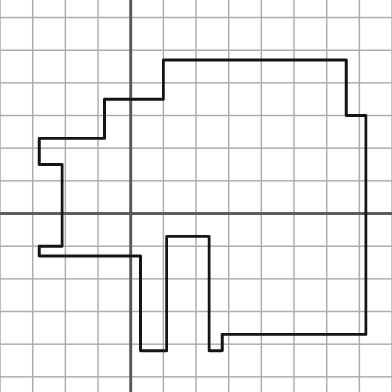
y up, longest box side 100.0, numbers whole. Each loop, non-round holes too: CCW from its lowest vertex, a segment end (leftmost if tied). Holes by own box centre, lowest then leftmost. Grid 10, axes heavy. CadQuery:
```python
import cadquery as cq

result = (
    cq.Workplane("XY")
    .moveTo(3.0, -42.0)
    .lineTo(11.0, -42.0)
    .lineTo(11.0, -7.0)
    .lineTo(24.0, -7.0)
    .lineTo(24.0, -42.0)
    .lineTo(28.0, -42.0)
    .lineTo(28.0, -37.0)
    .lineTo(72.0, -37.0)
    .lineTo(72.0, 30.0)
    .lineTo(66.0, 30.0)
    .lineTo(66.0, 47.0)
    .lineTo(10.0, 47.0)
    .lineTo(10.0, 35.0)
    .lineTo(-8.0, 35.0)
    .lineTo(-8.0, 23.0)
    .lineTo(-28.0, 23.0)
    .lineTo(-28.0, 15.0)
    .lineTo(-21.0, 15.0)
    .lineTo(-21.0, -10.0)
    .lineTo(-28.0, -10.0)
    .lineTo(-28.0, -13.0)
    .lineTo(3.0, -13.0)
    .close()
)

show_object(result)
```